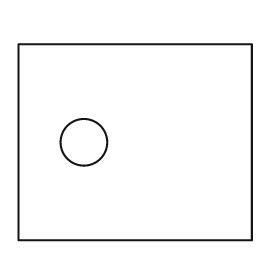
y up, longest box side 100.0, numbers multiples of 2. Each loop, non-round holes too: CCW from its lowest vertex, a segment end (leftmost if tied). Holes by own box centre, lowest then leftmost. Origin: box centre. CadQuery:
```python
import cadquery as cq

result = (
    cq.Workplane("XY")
    .moveTo(-50.0, -42.0)
    .lineTo(50.0, -42.0)
    .lineTo(50.0, 42.0)
    .lineTo(-50.0, 42.0)
    .close()
    .moveTo(-22.0, 0.0)
    .circle(10.0)
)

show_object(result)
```